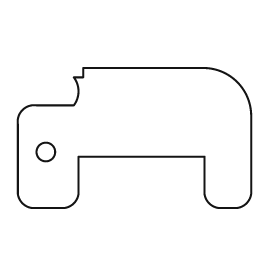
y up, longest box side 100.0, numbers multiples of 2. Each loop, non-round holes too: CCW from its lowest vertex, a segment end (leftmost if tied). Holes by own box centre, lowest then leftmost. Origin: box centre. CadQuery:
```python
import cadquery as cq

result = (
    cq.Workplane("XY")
    .moveTo(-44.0, -30.0)
    .lineTo(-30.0, -30.0)
    .threePointArc((-26.0, -28.0), (-24.0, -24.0))
    .lineTo(-24.0, -8.0)
    .lineTo(30.0, -8.0)
    .lineTo(30.0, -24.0)
    .threePointArc((32.0, -28.0), (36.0, -30.0))
    .lineTo(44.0, -30.0)
    .threePointArc((48.0, -28.0), (50.0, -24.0))
    .lineTo(50.0, 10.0)
    .threePointArc((44.0, 24.0), (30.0, 30.0))
    .lineTo(-22.0, 30.0)
    .lineTo(-22.0, 26.0)
    .lineTo(-26.0, 26.0)
    .threePointArc((-24.0, 20.0), (-26.0, 14.0))
    .lineTo(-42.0, 14.0)
    .threePointArc((-48.0, 12.0), (-50.0, 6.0))
    .lineTo(-50.0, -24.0)
    .threePointArc((-48.0, -28.0), (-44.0, -30.0))
    .close()
    .moveTo(-38.0, -6.0)
    .circle(4.0)
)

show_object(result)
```